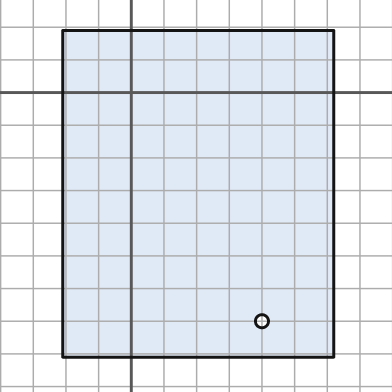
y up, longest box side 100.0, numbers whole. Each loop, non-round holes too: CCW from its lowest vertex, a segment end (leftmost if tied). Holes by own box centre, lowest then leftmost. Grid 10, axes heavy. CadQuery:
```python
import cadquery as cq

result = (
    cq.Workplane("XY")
    .moveTo(-21.0, -81.0)
    .lineTo(62.0, -81.0)
    .lineTo(62.0, 19.0)
    .lineTo(-21.0, 19.0)
    .close()
    .moveTo(40.0, -70.0)
    .circle(2.0)
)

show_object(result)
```